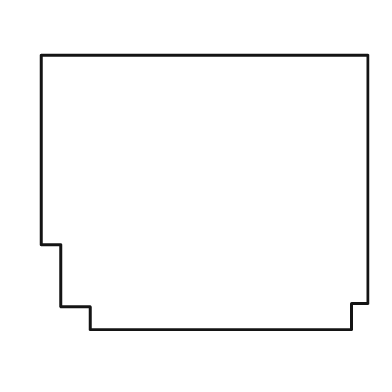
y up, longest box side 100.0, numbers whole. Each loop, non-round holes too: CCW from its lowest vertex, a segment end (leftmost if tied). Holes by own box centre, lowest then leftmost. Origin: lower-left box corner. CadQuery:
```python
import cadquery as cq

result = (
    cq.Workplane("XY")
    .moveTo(15.0, 0.0)
    .lineTo(95.0, 0.0)
    .lineTo(95.0, 8.0)
    .lineTo(100.0, 8.0)
    .lineTo(100.0, 84.0)
    .lineTo(0.0, 84.0)
    .lineTo(0.0, 26.0)
    .lineTo(6.0, 26.0)
    .lineTo(6.0, 7.0)
    .lineTo(15.0, 7.0)
    .close()
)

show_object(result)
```